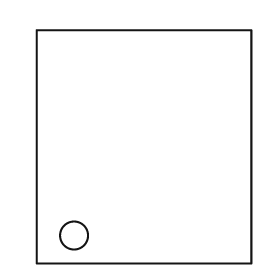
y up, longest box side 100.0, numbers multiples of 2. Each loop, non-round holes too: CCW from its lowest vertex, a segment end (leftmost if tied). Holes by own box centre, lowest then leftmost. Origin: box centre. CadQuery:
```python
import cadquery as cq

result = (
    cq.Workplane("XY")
    .moveTo(-46.0, -50.0)
    .lineTo(46.0, -50.0)
    .lineTo(46.0, 50.0)
    .lineTo(-46.0, 50.0)
    .close()
    .moveTo(-30.0, -38.0)
    .circle(6.0)
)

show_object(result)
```